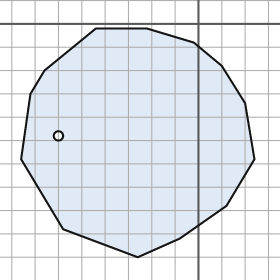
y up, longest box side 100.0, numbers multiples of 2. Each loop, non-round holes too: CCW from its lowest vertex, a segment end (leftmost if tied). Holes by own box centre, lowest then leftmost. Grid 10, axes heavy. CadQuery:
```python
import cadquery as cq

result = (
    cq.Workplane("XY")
    .moveTo(-26.0, -100.0)
    .lineTo(-8.0, -92.0)
    .lineTo(12.0, -78.0)
    .lineTo(24.0, -58.0)
    .lineTo(20.0, -34.0)
    .lineTo(10.0, -18.0)
    .lineTo(-2.0, -8.0)
    .lineTo(-22.0, -2.0)
    .lineTo(-44.0, -2.0)
    .lineTo(-66.0, -20.0)
    .lineTo(-72.0, -30.0)
    .lineTo(-76.0, -58.0)
    .lineTo(-58.0, -88.0)
    .close()
    .moveTo(-60.0, -48.0)
    .circle(2.0)
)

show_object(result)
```